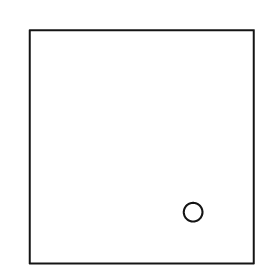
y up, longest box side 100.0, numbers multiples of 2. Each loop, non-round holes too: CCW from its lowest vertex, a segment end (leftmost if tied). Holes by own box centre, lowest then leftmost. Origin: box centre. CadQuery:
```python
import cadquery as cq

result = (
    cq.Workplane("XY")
    .moveTo(-48.0, -50.0)
    .lineTo(48.0, -50.0)
    .lineTo(48.0, 50.0)
    .lineTo(-48.0, 50.0)
    .close()
    .moveTo(22.0, -28.0)
    .circle(4.0)
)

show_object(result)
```